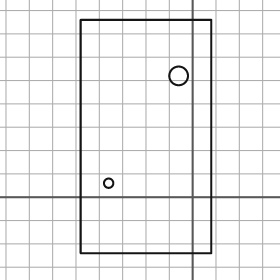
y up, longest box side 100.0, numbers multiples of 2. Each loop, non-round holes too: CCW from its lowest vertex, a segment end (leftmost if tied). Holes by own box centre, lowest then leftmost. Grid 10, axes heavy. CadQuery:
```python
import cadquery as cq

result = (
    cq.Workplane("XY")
    .moveTo(-48.0, -24.0)
    .lineTo(8.0, -24.0)
    .lineTo(8.0, 76.0)
    .lineTo(-48.0, 76.0)
    .close()
    .moveTo(-36.0, 6.0)
    .circle(2.0)
    .moveTo(-6.0, 52.0)
    .circle(4.0)
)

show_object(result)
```